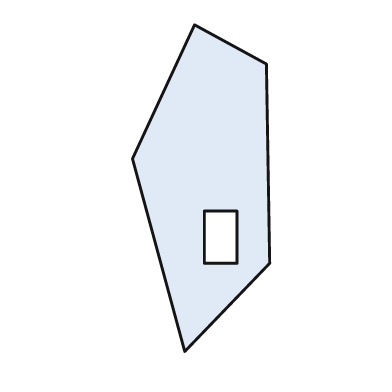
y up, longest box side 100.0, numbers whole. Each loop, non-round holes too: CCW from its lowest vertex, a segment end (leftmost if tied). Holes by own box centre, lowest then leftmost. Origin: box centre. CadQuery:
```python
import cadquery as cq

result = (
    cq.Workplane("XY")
    .moveTo(-5.0, -50.0)
    .lineTo(21.0, -23.0)
    .lineTo(20.0, 38.0)
    .lineTo(-2.0, 50.0)
    .lineTo(-21.0, 9.0)
    .close()
    .moveTo(1.0, -23.0)
    .lineTo(11.0, -23.0)
    .lineTo(11.0, -7.0)
    .lineTo(1.0, -7.0)
    .close()
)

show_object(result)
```